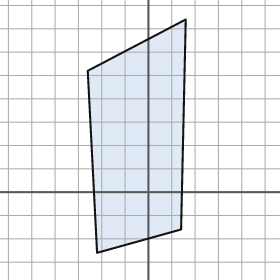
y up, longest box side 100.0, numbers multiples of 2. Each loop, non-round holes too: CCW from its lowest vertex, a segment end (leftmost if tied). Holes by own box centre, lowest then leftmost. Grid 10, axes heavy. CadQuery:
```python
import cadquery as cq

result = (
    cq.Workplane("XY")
    .moveTo(-22.0, -26.0)
    .lineTo(14.0, -16.0)
    .lineTo(16.0, 74.0)
    .lineTo(-26.0, 52.0)
    .close()
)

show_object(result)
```